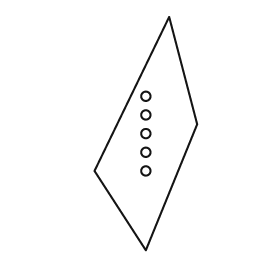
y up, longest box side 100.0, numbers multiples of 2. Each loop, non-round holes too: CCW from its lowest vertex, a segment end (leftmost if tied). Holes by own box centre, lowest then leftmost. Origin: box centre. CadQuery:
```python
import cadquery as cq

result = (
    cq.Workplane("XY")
    .moveTo(0.0, -50.0)
    .lineTo(22.0, 4.0)
    .lineTo(10.0, 50.0)
    .lineTo(-22.0, -16.0)
    .close()
    .moveTo(0.0, -16.0)
    .circle(2.0)
    .moveTo(0.0, -8.0)
    .circle(2.0)
    .moveTo(0.0, 0.0)
    .circle(2.0)
    .moveTo(0.0, 8.0)
    .circle(2.0)
    .moveTo(0.0, 16.0)
    .circle(2.0)
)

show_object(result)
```